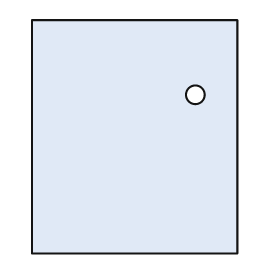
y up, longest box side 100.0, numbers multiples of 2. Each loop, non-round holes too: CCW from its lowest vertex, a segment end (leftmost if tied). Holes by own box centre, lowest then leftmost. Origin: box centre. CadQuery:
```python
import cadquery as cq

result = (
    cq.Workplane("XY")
    .moveTo(-44.0, -50.0)
    .lineTo(44.0, -50.0)
    .lineTo(44.0, 50.0)
    .lineTo(-44.0, 50.0)
    .close()
    .moveTo(26.0, 18.0)
    .circle(4.0)
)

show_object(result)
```